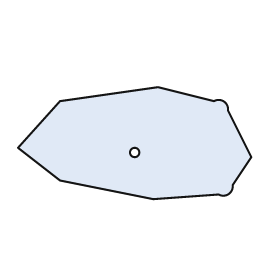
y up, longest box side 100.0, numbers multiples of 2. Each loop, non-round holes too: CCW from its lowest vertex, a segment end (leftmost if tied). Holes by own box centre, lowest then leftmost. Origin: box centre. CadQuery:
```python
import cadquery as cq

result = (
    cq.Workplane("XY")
    .moveTo(8.0, -24.0)
    .lineTo(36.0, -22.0)
    .threePointArc((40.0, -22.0), (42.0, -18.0))
    .lineTo(50.0, -6.0)
    .lineTo(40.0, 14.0)
    .threePointArc((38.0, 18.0), (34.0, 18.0))
    .lineTo(10.0, 24.0)
    .lineTo(-32.0, 18.0)
    .lineTo(-50.0, -2.0)
    .lineTo(-32.0, -16.0)
    .close()
    .moveTo(0.0, -4.0)
    .circle(2.0)
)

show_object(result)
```